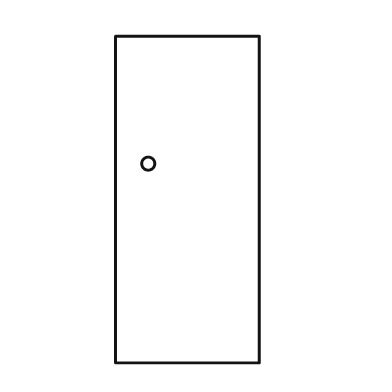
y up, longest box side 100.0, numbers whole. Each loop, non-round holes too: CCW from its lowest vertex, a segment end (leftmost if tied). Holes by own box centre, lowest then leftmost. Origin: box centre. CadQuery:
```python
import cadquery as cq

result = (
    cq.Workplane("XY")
    .moveTo(-22.0, -50.0)
    .lineTo(22.0, -50.0)
    .lineTo(22.0, 50.0)
    .lineTo(-22.0, 50.0)
    .close()
    .moveTo(-12.0, 11.0)
    .circle(2.0)
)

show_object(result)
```